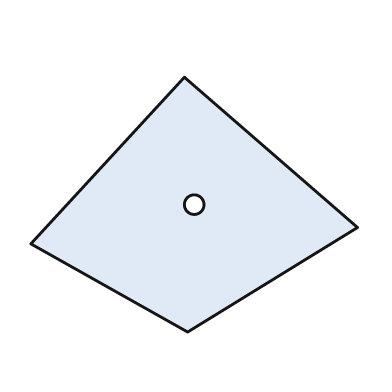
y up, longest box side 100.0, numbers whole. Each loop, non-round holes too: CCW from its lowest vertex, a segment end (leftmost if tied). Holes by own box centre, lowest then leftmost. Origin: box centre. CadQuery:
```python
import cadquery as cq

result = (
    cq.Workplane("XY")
    .moveTo(-2.0, -39.0)
    .lineTo(50.0, -7.0)
    .lineTo(-3.0, 39.0)
    .lineTo(-50.0, -12.0)
    .close()
    .moveTo(0.0, 0.0)
    .circle(3.0)
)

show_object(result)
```